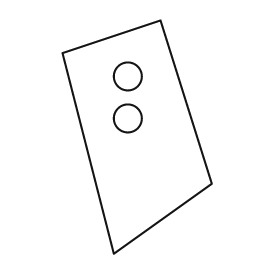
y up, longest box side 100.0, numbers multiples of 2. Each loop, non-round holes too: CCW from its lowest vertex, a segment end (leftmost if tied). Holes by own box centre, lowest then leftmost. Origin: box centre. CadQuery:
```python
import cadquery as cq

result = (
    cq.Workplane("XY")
    .moveTo(-10.0, -50.0)
    .lineTo(32.0, -20.0)
    .lineTo(10.0, 50.0)
    .lineTo(-32.0, 36.0)
    .close()
    .moveTo(-4.0, 8.0)
    .circle(6.0)
    .moveTo(-4.0, 26.0)
    .circle(6.0)
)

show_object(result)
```